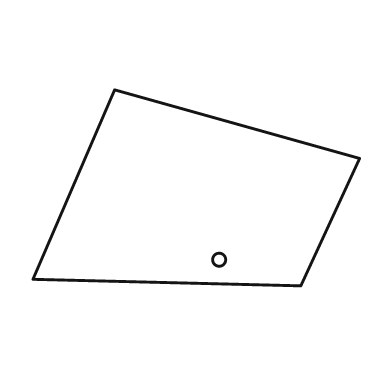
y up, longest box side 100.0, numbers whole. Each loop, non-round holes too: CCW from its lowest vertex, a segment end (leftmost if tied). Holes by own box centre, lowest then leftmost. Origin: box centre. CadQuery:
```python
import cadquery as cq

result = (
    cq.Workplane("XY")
    .moveTo(32.0, -30.0)
    .lineTo(50.0, 9.0)
    .lineTo(-25.0, 30.0)
    .lineTo(-50.0, -28.0)
    .close()
    .moveTo(7.0, -22.0)
    .circle(2.0)
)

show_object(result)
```